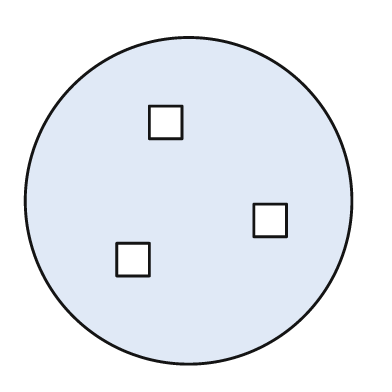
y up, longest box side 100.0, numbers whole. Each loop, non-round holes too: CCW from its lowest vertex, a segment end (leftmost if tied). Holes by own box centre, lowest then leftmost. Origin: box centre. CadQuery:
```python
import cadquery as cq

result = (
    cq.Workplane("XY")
    .moveTo(0.0, 0.0)
    .circle(50.0)
    .moveTo(-22.0, -23.0)
    .lineTo(-12.0, -23.0)
    .lineTo(-12.0, -13.0)
    .lineTo(-22.0, -13.0)
    .close()
    .moveTo(20.0, -11.0)
    .lineTo(30.0, -11.0)
    .lineTo(30.0, -1.0)
    .lineTo(20.0, -1.0)
    .close()
    .moveTo(-12.0, 19.0)
    .lineTo(-2.0, 19.0)
    .lineTo(-2.0, 29.0)
    .lineTo(-12.0, 29.0)
    .close()
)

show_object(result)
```